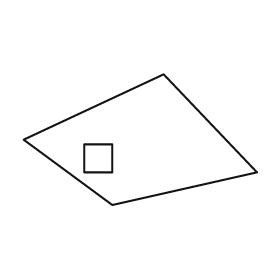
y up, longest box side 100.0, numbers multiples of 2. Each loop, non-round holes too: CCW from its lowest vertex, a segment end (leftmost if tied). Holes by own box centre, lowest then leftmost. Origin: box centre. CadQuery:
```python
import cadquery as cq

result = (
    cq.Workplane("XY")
    .moveTo(-12.0, -28.0)
    .lineTo(50.0, -14.0)
    .lineTo(10.0, 28.0)
    .lineTo(-50.0, 0.0)
    .close()
    .moveTo(-24.0, -14.0)
    .lineTo(-12.0, -14.0)
    .lineTo(-12.0, -2.0)
    .lineTo(-24.0, -2.0)
    .close()
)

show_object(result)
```